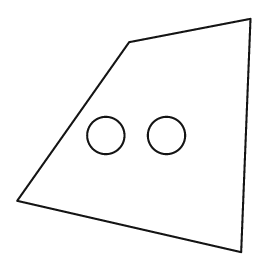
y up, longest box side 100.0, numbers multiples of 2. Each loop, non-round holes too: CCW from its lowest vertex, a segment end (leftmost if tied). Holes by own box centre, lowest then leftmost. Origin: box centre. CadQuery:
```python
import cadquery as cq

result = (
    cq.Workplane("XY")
    .moveTo(46.0, -50.0)
    .lineTo(50.0, 50.0)
    .lineTo(-2.0, 40.0)
    .lineTo(-50.0, -28.0)
    .close()
    .moveTo(-12.0, 0.0)
    .circle(8.0)
    .moveTo(14.0, 0.0)
    .circle(8.0)
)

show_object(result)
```